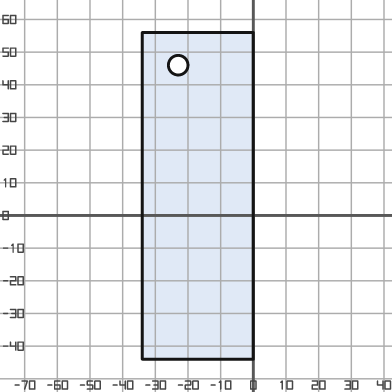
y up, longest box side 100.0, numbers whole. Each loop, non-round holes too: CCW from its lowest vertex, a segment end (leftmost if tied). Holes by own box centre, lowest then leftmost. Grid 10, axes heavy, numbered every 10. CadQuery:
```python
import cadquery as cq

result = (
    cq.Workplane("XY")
    .moveTo(-34.0, -44.0)
    .lineTo(0.0, -44.0)
    .lineTo(0.0, 56.0)
    .lineTo(-34.0, 56.0)
    .close()
    .moveTo(-23.0, 46.0)
    .circle(3.0)
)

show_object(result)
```